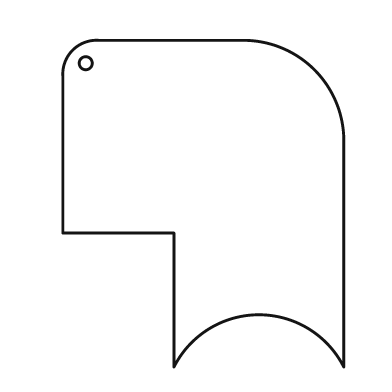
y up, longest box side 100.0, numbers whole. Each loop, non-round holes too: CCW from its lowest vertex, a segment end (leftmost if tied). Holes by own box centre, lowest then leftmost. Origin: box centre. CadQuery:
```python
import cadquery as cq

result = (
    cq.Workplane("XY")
    .moveTo(-9.0, -50.0)
    .threePointArc((17.0, -34.0), (43.0, -50.0))
    .lineTo(43.0, 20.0)
    .threePointArc((34.0, 41.0), (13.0, 50.0))
    .lineTo(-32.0, 50.0)
    .threePointArc((-40.0, 47.0), (-43.0, 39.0))
    .lineTo(-43.0, -9.0)
    .lineTo(-9.0, -9.0)
    .close()
    .moveTo(-36.0, 43.0)
    .circle(2.0)
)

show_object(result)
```